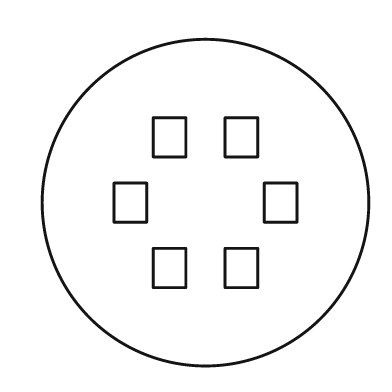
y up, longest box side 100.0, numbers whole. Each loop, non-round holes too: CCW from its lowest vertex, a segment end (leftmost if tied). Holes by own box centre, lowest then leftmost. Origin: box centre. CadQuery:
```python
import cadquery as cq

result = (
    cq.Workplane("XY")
    .moveTo(0.0, 0.0)
    .circle(50.0)
    .moveTo(-16.0, -26.0)
    .lineTo(-6.0, -26.0)
    .lineTo(-6.0, -14.0)
    .lineTo(-16.0, -14.0)
    .close()
    .moveTo(6.0, -26.0)
    .lineTo(16.0, -26.0)
    .lineTo(16.0, -14.0)
    .lineTo(6.0, -14.0)
    .close()
    .moveTo(-28.0, -6.0)
    .lineTo(-18.0, -6.0)
    .lineTo(-18.0, 6.0)
    .lineTo(-28.0, 6.0)
    .close()
    .moveTo(18.0, -6.0)
    .lineTo(28.0, -6.0)
    .lineTo(28.0, 6.0)
    .lineTo(18.0, 6.0)
    .close()
    .moveTo(-16.0, 14.0)
    .lineTo(-6.0, 14.0)
    .lineTo(-6.0, 26.0)
    .lineTo(-16.0, 26.0)
    .close()
    .moveTo(6.0, 14.0)
    .lineTo(16.0, 14.0)
    .lineTo(16.0, 26.0)
    .lineTo(6.0, 26.0)
    .close()
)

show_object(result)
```